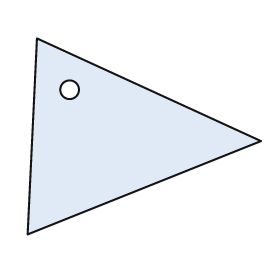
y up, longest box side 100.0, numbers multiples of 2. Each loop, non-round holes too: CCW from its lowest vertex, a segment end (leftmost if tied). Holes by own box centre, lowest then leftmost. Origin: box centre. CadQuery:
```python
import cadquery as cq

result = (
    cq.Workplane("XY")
    .moveTo(-50.0, -42.0)
    .lineTo(50.0, -2.0)
    .lineTo(-46.0, 42.0)
    .close()
    .moveTo(-32.0, 20.0)
    .circle(4.0)
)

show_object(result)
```